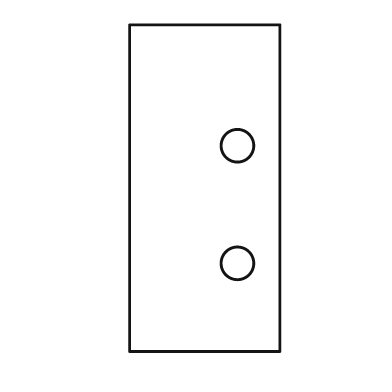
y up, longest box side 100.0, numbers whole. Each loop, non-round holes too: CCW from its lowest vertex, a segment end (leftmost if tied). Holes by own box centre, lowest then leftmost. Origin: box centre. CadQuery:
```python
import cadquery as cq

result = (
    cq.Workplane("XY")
    .moveTo(-23.0, -50.0)
    .lineTo(23.0, -50.0)
    .lineTo(23.0, 50.0)
    .lineTo(-23.0, 50.0)
    .close()
    .moveTo(10.0, -23.0)
    .circle(5.0)
    .moveTo(10.0, 13.0)
    .circle(5.0)
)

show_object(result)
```